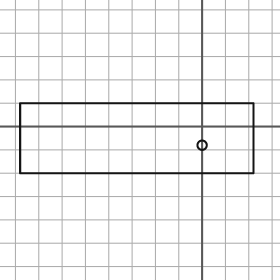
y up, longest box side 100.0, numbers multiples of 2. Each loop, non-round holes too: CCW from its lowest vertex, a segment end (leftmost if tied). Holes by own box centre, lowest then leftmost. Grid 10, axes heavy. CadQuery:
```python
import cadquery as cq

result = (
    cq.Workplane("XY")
    .moveTo(-78.0, -20.0)
    .lineTo(22.0, -20.0)
    .lineTo(22.0, 10.0)
    .lineTo(-78.0, 10.0)
    .close()
    .moveTo(0.0, -8.0)
    .circle(2.0)
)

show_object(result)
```